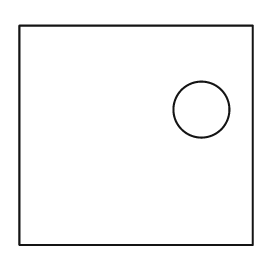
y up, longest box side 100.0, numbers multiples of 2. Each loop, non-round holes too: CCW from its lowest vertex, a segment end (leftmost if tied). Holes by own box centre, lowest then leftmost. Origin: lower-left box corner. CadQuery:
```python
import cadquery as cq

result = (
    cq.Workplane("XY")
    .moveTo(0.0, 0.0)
    .lineTo(100.0, 0.0)
    .lineTo(100.0, 94.0)
    .lineTo(0.0, 94.0)
    .close()
    .moveTo(78.0, 58.0)
    .circle(12.0)
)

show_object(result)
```